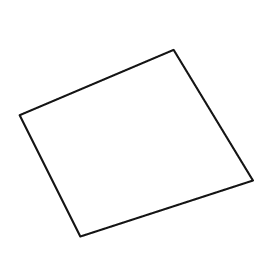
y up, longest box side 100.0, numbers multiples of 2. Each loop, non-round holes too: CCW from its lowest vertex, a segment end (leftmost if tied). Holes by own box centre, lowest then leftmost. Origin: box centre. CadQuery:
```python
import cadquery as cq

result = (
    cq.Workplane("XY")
    .moveTo(-24.0, -40.0)
    .lineTo(50.0, -16.0)
    .lineTo(16.0, 40.0)
    .lineTo(-50.0, 12.0)
    .close()
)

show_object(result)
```